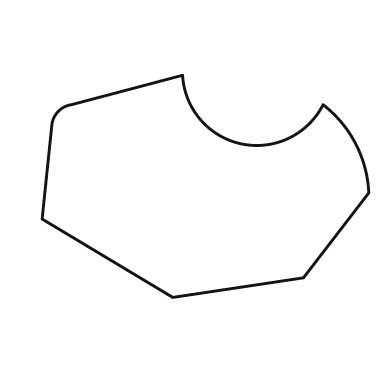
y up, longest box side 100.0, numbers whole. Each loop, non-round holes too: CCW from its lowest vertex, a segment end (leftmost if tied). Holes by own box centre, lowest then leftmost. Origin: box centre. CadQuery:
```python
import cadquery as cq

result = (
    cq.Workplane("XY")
    .moveTo(-10.0, -34.0)
    .lineTo(30.0, -28.0)
    .lineTo(50.0, -2.0)
    .threePointArc((46.0, 13.0), (36.0, 25.0))
    .threePointArc((11.0, 13.0), (-7.0, 34.0))
    .lineTo(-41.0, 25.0)
    .threePointArc((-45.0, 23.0), (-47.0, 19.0))
    .lineTo(-50.0, -10.0)
    .close()
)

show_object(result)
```